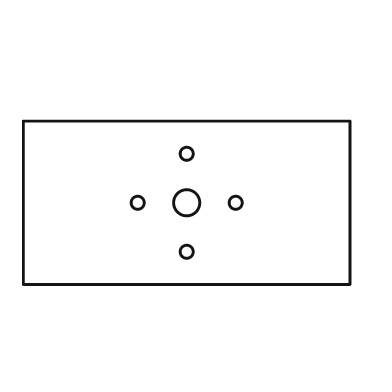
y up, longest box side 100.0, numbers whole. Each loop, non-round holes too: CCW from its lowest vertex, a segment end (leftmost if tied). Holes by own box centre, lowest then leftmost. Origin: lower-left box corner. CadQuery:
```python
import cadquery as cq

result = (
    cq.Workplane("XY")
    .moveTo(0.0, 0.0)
    .lineTo(100.0, 0.0)
    .lineTo(100.0, 50.0)
    .lineTo(0.0, 50.0)
    .close()
    .moveTo(50.0, 10.0)
    .circle(2.0)
    .moveTo(35.0, 25.0)
    .circle(2.0)
    .moveTo(50.0, 25.0)
    .circle(4.0)
    .moveTo(65.0, 25.0)
    .circle(2.0)
    .moveTo(50.0, 40.0)
    .circle(2.0)
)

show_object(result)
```